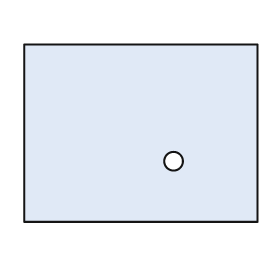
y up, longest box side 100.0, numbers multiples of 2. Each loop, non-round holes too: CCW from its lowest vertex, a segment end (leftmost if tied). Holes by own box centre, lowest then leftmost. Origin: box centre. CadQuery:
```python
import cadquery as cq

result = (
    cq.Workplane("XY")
    .moveTo(-50.0, -38.0)
    .lineTo(50.0, -38.0)
    .lineTo(50.0, 38.0)
    .lineTo(-50.0, 38.0)
    .close()
    .moveTo(14.0, -12.0)
    .circle(4.0)
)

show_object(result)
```